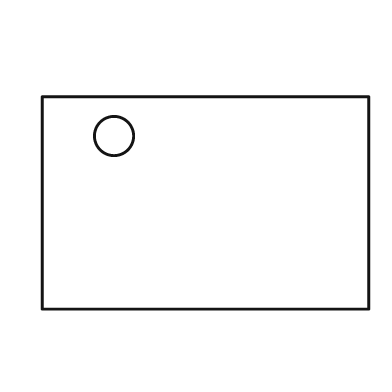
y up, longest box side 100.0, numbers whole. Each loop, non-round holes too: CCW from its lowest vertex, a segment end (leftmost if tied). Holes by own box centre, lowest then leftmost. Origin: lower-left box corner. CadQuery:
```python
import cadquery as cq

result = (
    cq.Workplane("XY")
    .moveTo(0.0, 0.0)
    .lineTo(100.0, 0.0)
    .lineTo(100.0, 65.0)
    .lineTo(0.0, 65.0)
    .close()
    .moveTo(22.0, 53.0)
    .circle(6.0)
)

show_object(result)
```